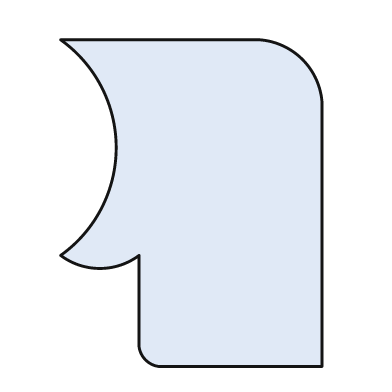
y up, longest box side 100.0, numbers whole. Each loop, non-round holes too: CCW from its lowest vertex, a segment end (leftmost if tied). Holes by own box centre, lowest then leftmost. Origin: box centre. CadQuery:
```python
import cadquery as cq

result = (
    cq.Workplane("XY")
    .moveTo(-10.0, -50.0)
    .lineTo(40.0, -50.0)
    .lineTo(40.0, 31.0)
    .threePointArc((34.0, 44.0), (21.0, 50.0))
    .lineTo(-40.0, 50.0)
    .threePointArc((-23.0, 17.0), (-40.0, -16.0))
    .threePointArc((-28.0, -20.0), (-16.0, -16.0))
    .lineTo(-16.0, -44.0)
    .threePointArc((-14.0, -48.0), (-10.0, -50.0))
    .close()
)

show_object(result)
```